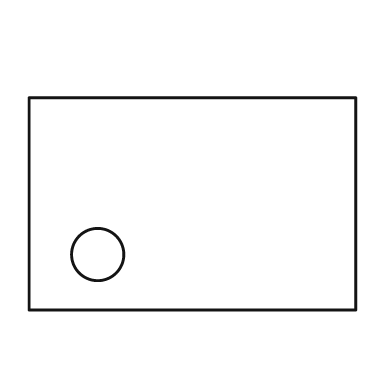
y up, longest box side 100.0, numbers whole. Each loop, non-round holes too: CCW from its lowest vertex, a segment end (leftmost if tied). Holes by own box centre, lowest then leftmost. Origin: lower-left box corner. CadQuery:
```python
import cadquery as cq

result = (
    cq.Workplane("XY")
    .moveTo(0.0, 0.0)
    .lineTo(100.0, 0.0)
    .lineTo(100.0, 65.0)
    .lineTo(0.0, 65.0)
    .close()
    .moveTo(21.0, 17.0)
    .circle(8.0)
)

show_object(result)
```